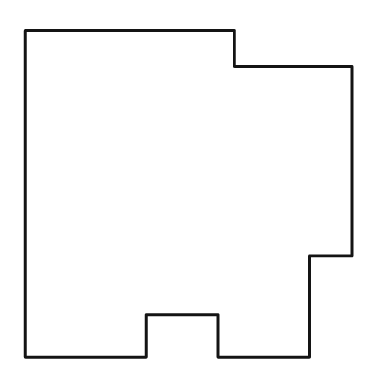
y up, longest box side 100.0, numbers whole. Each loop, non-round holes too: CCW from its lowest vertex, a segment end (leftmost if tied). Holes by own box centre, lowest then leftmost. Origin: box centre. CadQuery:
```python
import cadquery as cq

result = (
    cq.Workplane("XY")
    .moveTo(-50.0, -50.0)
    .lineTo(-13.0, -50.0)
    .lineTo(-13.0, -37.0)
    .lineTo(9.0, -37.0)
    .lineTo(9.0, -50.0)
    .lineTo(37.0, -50.0)
    .lineTo(37.0, -19.0)
    .lineTo(50.0, -19.0)
    .lineTo(50.0, 39.0)
    .lineTo(14.0, 39.0)
    .lineTo(14.0, 50.0)
    .lineTo(-50.0, 50.0)
    .close()
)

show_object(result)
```